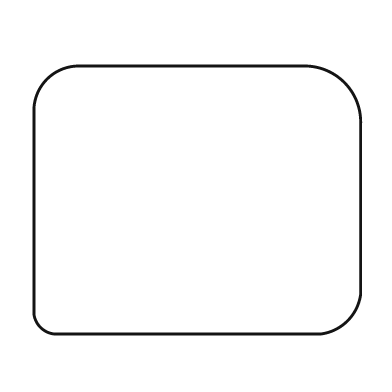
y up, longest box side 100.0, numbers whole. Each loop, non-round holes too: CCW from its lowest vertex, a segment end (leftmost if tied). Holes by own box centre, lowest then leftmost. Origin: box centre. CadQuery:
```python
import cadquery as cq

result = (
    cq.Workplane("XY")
    .moveTo(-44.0, -41.0)
    .lineTo(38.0, -41.0)
    .threePointArc((46.0, -37.0), (50.0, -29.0))
    .lineTo(50.0, 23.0)
    .threePointArc((45.0, 36.0), (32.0, 41.0))
    .lineTo(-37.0, 41.0)
    .threePointArc((-46.0, 37.0), (-50.0, 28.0))
    .lineTo(-50.0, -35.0)
    .threePointArc((-48.0, -39.0), (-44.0, -41.0))
    .close()
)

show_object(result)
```